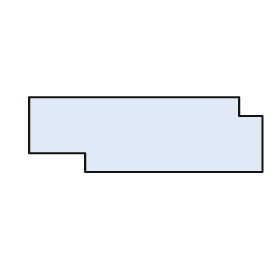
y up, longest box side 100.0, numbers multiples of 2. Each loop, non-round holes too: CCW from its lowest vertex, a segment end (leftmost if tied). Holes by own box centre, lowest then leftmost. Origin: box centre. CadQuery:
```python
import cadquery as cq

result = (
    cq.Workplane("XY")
    .moveTo(-26.0, -16.0)
    .lineTo(50.0, -16.0)
    .lineTo(50.0, 8.0)
    .lineTo(40.0, 8.0)
    .lineTo(40.0, 16.0)
    .lineTo(-50.0, 16.0)
    .lineTo(-50.0, -8.0)
    .lineTo(-26.0, -8.0)
    .close()
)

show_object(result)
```